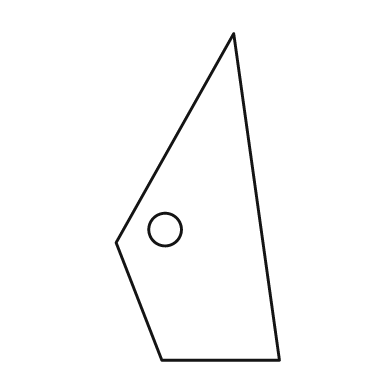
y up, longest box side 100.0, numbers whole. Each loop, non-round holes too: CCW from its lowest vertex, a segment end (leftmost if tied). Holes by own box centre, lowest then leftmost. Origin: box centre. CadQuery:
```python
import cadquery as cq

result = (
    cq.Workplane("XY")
    .moveTo(-11.0, -50.0)
    .lineTo(25.0, -50.0)
    .lineTo(11.0, 50.0)
    .lineTo(-25.0, -14.0)
    .close()
    .moveTo(-10.0, -10.0)
    .circle(5.0)
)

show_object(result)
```